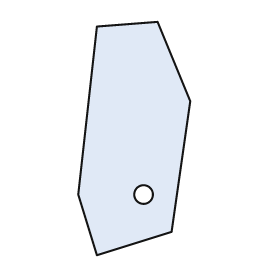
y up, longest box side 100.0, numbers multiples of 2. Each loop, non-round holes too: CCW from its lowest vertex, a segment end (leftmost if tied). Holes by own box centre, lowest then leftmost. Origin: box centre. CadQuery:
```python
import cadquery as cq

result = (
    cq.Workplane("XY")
    .moveTo(-16.0, -50.0)
    .lineTo(16.0, -40.0)
    .lineTo(24.0, 16.0)
    .lineTo(10.0, 50.0)
    .lineTo(-16.0, 48.0)
    .lineTo(-24.0, -24.0)
    .close()
    .moveTo(4.0, -24.0)
    .circle(4.0)
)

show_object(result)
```